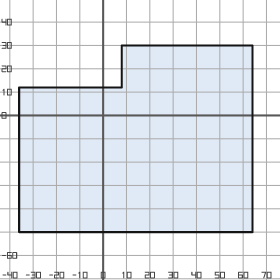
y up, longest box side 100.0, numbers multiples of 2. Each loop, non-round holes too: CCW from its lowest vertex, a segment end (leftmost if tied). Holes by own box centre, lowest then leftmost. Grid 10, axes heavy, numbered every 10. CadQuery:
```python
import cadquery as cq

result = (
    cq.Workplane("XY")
    .moveTo(-36.0, -50.0)
    .lineTo(64.0, -50.0)
    .lineTo(64.0, 30.0)
    .lineTo(8.0, 30.0)
    .lineTo(8.0, 12.0)
    .lineTo(-36.0, 12.0)
    .close()
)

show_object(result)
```